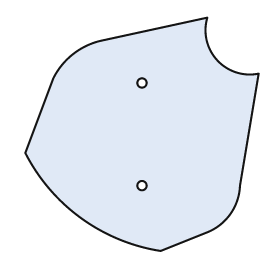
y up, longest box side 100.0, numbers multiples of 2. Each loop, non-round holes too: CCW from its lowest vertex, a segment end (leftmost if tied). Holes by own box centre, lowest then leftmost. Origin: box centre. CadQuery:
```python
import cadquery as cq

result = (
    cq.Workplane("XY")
    .moveTo(8.0, -50.0)
    .lineTo(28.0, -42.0)
    .threePointArc((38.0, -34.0), (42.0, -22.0))
    .lineTo(50.0, 26.0)
    .threePointArc((32.0, 32.0), (28.0, 50.0))
    .lineTo(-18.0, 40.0)
    .threePointArc((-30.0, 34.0), (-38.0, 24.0))
    .lineTo(-50.0, -8.0)
    .threePointArc((-26.0, -36.0), (8.0, -50.0))
    .close()
    .moveTo(0.0, -22.0)
    .circle(2.0)
    .moveTo(0.0, 22.0)
    .circle(2.0)
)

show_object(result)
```